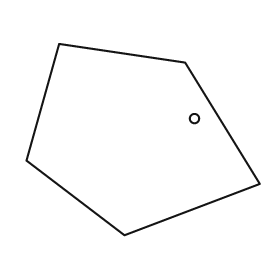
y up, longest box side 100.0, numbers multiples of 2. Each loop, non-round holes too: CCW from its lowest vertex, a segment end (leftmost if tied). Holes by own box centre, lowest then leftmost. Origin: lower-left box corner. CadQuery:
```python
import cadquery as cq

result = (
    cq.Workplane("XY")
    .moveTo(42.0, 0.0)
    .lineTo(100.0, 22.0)
    .lineTo(68.0, 74.0)
    .lineTo(14.0, 82.0)
    .lineTo(0.0, 32.0)
    .close()
    .moveTo(72.0, 50.0)
    .circle(2.0)
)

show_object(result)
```